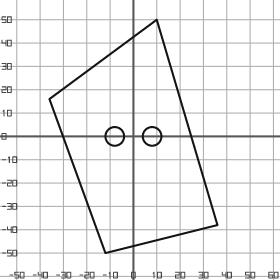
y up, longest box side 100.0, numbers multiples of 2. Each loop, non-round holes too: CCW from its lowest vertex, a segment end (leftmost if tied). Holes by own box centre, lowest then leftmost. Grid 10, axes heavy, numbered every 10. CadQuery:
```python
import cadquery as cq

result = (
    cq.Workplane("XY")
    .moveTo(-12.0, -50.0)
    .lineTo(36.0, -38.0)
    .lineTo(10.0, 50.0)
    .lineTo(-36.0, 16.0)
    .close()
    .moveTo(-8.0, 0.0)
    .circle(4.0)
    .moveTo(8.0, 0.0)
    .circle(4.0)
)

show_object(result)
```